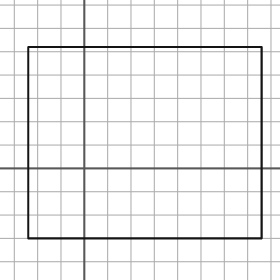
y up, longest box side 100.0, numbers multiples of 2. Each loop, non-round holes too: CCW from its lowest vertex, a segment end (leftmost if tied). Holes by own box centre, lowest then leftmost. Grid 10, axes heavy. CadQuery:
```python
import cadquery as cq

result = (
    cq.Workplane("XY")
    .moveTo(-24.0, -30.0)
    .lineTo(76.0, -30.0)
    .lineTo(76.0, 52.0)
    .lineTo(-24.0, 52.0)
    .close()
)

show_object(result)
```